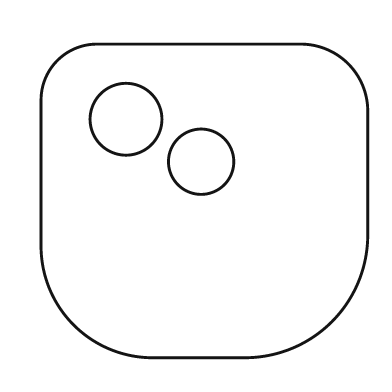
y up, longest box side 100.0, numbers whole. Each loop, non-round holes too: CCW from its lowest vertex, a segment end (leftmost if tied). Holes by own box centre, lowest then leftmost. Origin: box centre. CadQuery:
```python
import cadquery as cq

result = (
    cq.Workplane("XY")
    .moveTo(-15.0, -48.0)
    .lineTo(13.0, -48.0)
    .threePointArc((39.0, -37.0), (50.0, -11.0))
    .lineTo(50.0, 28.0)
    .threePointArc((44.0, 42.0), (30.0, 48.0))
    .lineTo(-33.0, 48.0)
    .threePointArc((-45.0, 43.0), (-50.0, 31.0))
    .lineTo(-50.0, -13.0)
    .threePointArc((-40.0, -38.0), (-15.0, -48.0))
    .close()
    .moveTo(-1.0, 12.0)
    .circle(10.0)
    .moveTo(-24.0, 25.0)
    .circle(11.0)
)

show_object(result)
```